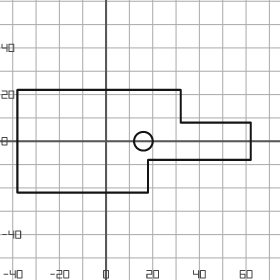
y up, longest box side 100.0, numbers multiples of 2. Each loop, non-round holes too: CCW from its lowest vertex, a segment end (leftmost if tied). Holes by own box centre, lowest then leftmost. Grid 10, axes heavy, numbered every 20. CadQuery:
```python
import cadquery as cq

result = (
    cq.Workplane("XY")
    .moveTo(-38.0, -22.0)
    .lineTo(18.0, -22.0)
    .lineTo(18.0, -8.0)
    .lineTo(62.0, -8.0)
    .lineTo(62.0, 8.0)
    .lineTo(32.0, 8.0)
    .lineTo(32.0, 22.0)
    .lineTo(-38.0, 22.0)
    .close()
    .moveTo(16.0, 0.0)
    .circle(4.0)
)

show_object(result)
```